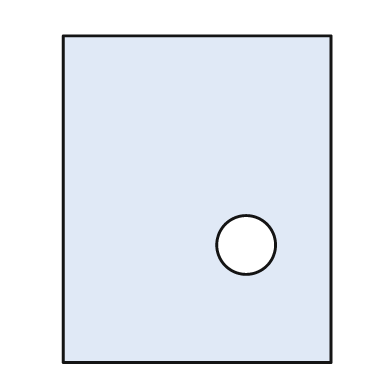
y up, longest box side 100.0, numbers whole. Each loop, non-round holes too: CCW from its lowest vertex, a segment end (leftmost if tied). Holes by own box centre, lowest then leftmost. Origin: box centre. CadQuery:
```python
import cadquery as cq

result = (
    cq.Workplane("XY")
    .moveTo(-41.0, -50.0)
    .lineTo(41.0, -50.0)
    .lineTo(41.0, 50.0)
    .lineTo(-41.0, 50.0)
    .close()
    .moveTo(15.0, -14.0)
    .circle(9.0)
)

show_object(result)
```